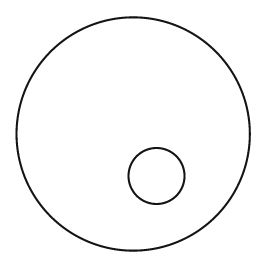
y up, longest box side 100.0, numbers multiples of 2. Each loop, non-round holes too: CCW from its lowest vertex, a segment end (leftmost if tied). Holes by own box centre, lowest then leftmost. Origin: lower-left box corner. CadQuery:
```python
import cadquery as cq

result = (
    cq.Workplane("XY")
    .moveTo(50.0, 50.0)
    .circle(50.0)
    .moveTo(60.0, 32.0)
    .circle(12.0)
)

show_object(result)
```